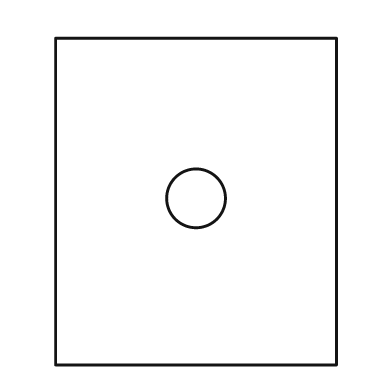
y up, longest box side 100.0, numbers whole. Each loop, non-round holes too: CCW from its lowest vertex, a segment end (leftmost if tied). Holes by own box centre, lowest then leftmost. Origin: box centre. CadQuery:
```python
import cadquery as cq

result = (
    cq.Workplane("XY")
    .moveTo(-43.0, -50.0)
    .lineTo(43.0, -50.0)
    .lineTo(43.0, 50.0)
    .lineTo(-43.0, 50.0)
    .close()
    .moveTo(0.0, 1.0)
    .circle(9.0)
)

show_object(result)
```